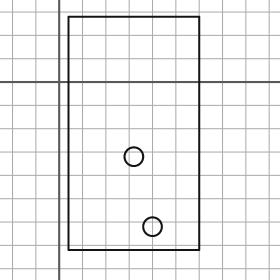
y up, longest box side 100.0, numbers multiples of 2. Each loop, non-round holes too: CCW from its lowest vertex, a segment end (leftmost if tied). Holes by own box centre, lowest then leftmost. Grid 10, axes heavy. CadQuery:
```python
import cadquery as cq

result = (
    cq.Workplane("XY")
    .moveTo(4.0, -72.0)
    .lineTo(60.0, -72.0)
    .lineTo(60.0, 28.0)
    .lineTo(4.0, 28.0)
    .close()
    .moveTo(40.0, -62.0)
    .circle(4.0)
    .moveTo(32.0, -32.0)
    .circle(4.0)
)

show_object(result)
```